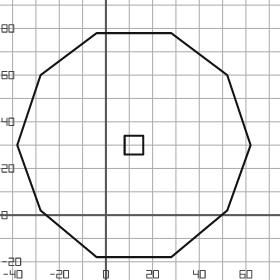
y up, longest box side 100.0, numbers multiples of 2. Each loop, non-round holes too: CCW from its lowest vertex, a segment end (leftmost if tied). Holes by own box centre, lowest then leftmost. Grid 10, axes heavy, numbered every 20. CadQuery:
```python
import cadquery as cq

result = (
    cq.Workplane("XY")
    .moveTo(-4.0, -18.0)
    .lineTo(28.0, -18.0)
    .lineTo(52.0, 2.0)
    .lineTo(62.0, 30.0)
    .lineTo(52.0, 60.0)
    .lineTo(28.0, 78.0)
    .lineTo(-4.0, 78.0)
    .lineTo(-28.0, 60.0)
    .lineTo(-38.0, 30.0)
    .lineTo(-28.0, 2.0)
    .close()
    .moveTo(8.0, 26.0)
    .lineTo(16.0, 26.0)
    .lineTo(16.0, 34.0)
    .lineTo(8.0, 34.0)
    .close()
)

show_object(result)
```